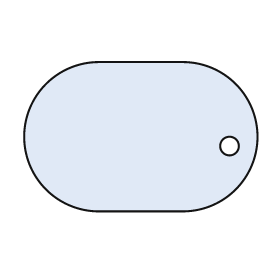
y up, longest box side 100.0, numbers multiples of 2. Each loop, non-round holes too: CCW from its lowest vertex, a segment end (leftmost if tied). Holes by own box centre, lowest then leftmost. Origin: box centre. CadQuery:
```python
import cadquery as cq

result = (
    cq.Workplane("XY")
    .moveTo(-18.0, -32.0)
    .lineTo(18.0, -32.0)
    .threePointArc((50.0, 0.0), (18.0, 32.0))
    .lineTo(-18.0, 32.0)
    .threePointArc((-50.0, 0.0), (-18.0, -32.0))
    .close()
    .moveTo(38.0, -4.0)
    .circle(4.0)
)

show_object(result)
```